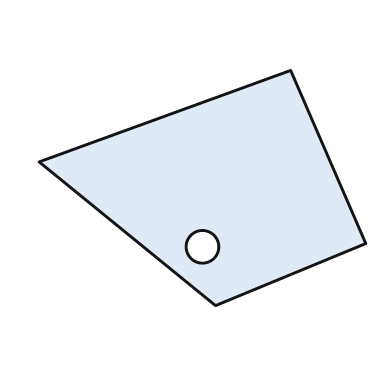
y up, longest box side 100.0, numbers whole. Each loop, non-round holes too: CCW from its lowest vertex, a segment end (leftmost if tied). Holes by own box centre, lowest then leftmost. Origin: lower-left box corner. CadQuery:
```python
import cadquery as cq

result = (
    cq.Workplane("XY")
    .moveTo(54.0, 0.0)
    .lineTo(100.0, 19.0)
    .lineTo(77.0, 72.0)
    .lineTo(0.0, 44.0)
    .close()
    .moveTo(50.0, 18.0)
    .circle(5.0)
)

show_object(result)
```